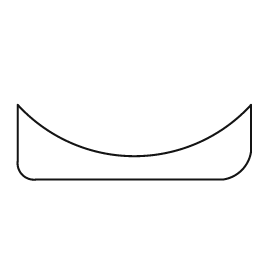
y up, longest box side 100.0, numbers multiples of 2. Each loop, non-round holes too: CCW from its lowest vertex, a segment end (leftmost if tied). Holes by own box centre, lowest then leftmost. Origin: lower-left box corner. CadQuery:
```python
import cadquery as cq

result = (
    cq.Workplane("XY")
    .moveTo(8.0, 0.0)
    .lineTo(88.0, 0.0)
    .threePointArc((96.0, 4.0), (100.0, 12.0))
    .lineTo(100.0, 32.0)
    .threePointArc((50.0, 10.0), (0.0, 32.0))
    .lineTo(0.0, 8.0)
    .threePointArc((2.0, 2.0), (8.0, 0.0))
    .close()
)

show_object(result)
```